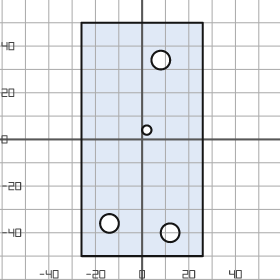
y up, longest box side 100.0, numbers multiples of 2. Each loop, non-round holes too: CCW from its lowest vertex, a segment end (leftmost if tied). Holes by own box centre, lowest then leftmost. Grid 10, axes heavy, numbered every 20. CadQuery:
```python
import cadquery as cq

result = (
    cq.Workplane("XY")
    .moveTo(-26.0, -50.0)
    .lineTo(26.0, -50.0)
    .lineTo(26.0, 50.0)
    .lineTo(-26.0, 50.0)
    .close()
    .moveTo(12.0, -40.0)
    .circle(4.0)
    .moveTo(-14.0, -36.0)
    .circle(4.0)
    .moveTo(2.0, 4.0)
    .circle(2.0)
    .moveTo(8.0, 34.0)
    .circle(4.0)
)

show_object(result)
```